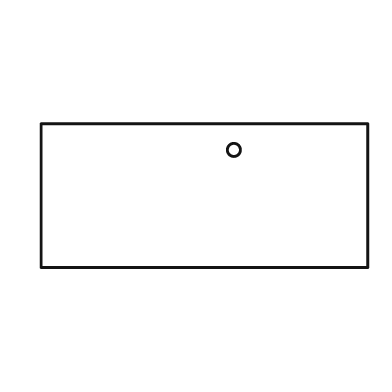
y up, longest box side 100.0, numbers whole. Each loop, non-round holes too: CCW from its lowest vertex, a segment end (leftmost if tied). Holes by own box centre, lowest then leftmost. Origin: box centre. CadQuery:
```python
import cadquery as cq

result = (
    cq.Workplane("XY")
    .moveTo(-50.0, -22.0)
    .lineTo(50.0, -22.0)
    .lineTo(50.0, 22.0)
    .lineTo(-50.0, 22.0)
    .close()
    .moveTo(9.0, 14.0)
    .circle(2.0)
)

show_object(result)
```